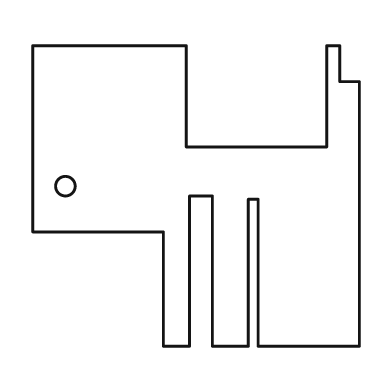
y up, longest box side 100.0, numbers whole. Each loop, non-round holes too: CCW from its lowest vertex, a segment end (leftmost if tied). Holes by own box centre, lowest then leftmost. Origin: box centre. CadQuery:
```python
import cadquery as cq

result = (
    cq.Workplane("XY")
    .moveTo(-10.0, -46.0)
    .lineTo(-2.0, -46.0)
    .lineTo(-2.0, 0.0)
    .lineTo(5.0, 0.0)
    .lineTo(5.0, -46.0)
    .lineTo(16.0, -46.0)
    .lineTo(16.0, -1.0)
    .lineTo(19.0, -1.0)
    .lineTo(19.0, -46.0)
    .lineTo(50.0, -46.0)
    .lineTo(50.0, 35.0)
    .lineTo(44.0, 35.0)
    .lineTo(44.0, 46.0)
    .lineTo(40.0, 46.0)
    .lineTo(40.0, 15.0)
    .lineTo(-3.0, 15.0)
    .lineTo(-3.0, 46.0)
    .lineTo(-50.0, 46.0)
    .lineTo(-50.0, -11.0)
    .lineTo(-10.0, -11.0)
    .close()
    .moveTo(-40.0, 3.0)
    .circle(3.0)
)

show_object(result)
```